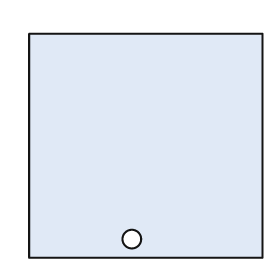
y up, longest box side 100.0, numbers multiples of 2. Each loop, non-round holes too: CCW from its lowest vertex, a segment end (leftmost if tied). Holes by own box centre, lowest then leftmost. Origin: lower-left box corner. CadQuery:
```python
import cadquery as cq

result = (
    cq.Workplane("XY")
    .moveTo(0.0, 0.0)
    .lineTo(100.0, 0.0)
    .lineTo(100.0, 96.0)
    .lineTo(0.0, 96.0)
    .close()
    .moveTo(44.0, 8.0)
    .circle(4.0)
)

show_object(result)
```